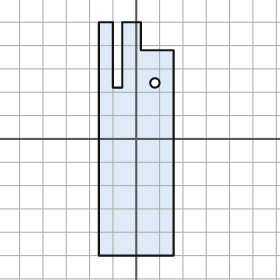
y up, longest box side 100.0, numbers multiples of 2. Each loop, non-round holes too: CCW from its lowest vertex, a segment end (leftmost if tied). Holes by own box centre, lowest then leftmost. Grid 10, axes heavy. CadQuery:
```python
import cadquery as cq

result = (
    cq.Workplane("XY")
    .moveTo(-16.0, -50.0)
    .lineTo(16.0, -50.0)
    .lineTo(16.0, 38.0)
    .lineTo(2.0, 38.0)
    .lineTo(2.0, 50.0)
    .lineTo(-6.0, 50.0)
    .lineTo(-6.0, 22.0)
    .lineTo(-10.0, 22.0)
    .lineTo(-10.0, 50.0)
    .lineTo(-16.0, 50.0)
    .close()
    .moveTo(8.0, 24.0)
    .circle(2.0)
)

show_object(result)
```